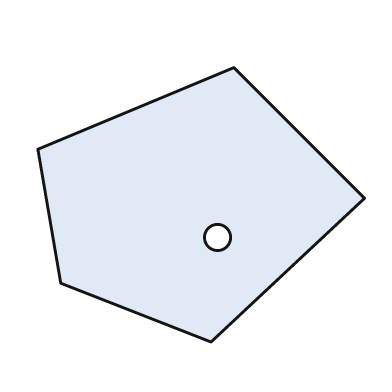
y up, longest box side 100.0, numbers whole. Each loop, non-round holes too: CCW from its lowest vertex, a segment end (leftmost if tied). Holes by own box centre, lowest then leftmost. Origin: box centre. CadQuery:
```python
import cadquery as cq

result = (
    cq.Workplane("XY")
    .moveTo(3.0, -42.0)
    .lineTo(50.0, 2.0)
    .lineTo(10.0, 42.0)
    .lineTo(-50.0, 17.0)
    .lineTo(-43.0, -24.0)
    .close()
    .moveTo(5.0, -10.0)
    .circle(4.0)
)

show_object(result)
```